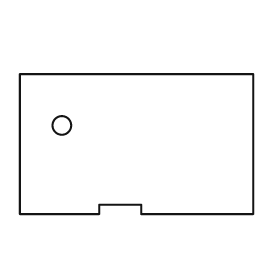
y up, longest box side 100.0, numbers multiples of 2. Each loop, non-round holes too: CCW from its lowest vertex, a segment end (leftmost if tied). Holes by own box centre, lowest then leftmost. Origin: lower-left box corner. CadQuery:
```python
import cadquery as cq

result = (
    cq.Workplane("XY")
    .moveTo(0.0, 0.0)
    .lineTo(34.0, 0.0)
    .lineTo(34.0, 4.0)
    .lineTo(52.0, 4.0)
    .lineTo(52.0, 0.0)
    .lineTo(100.0, 0.0)
    .lineTo(100.0, 60.0)
    .lineTo(0.0, 60.0)
    .close()
    .moveTo(18.0, 38.0)
    .circle(4.0)
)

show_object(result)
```